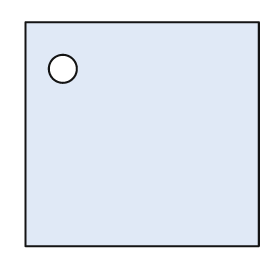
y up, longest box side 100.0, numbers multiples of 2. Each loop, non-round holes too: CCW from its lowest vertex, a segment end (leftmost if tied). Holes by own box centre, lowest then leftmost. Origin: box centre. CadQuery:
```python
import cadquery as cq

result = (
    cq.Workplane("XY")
    .moveTo(-50.0, -48.0)
    .lineTo(50.0, -48.0)
    .lineTo(50.0, 48.0)
    .lineTo(-50.0, 48.0)
    .close()
    .moveTo(-34.0, 28.0)
    .circle(6.0)
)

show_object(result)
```